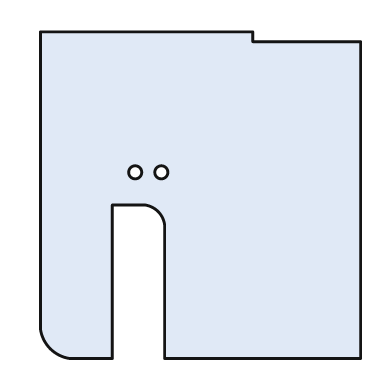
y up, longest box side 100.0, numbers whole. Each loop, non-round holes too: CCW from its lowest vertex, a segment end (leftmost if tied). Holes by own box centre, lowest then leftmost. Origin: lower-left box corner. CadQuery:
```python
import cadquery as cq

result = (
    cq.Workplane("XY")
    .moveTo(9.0, 0.0)
    .lineTo(22.0, 0.0)
    .lineTo(22.0, 47.0)
    .lineTo(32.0, 47.0)
    .threePointArc((36.0, 45.0), (38.0, 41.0))
    .lineTo(38.0, 0.0)
    .lineTo(98.0, 0.0)
    .lineTo(98.0, 97.0)
    .lineTo(65.0, 97.0)
    .lineTo(65.0, 100.0)
    .lineTo(0.0, 100.0)
    .lineTo(0.0, 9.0)
    .threePointArc((3.0, 3.0), (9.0, 0.0))
    .close()
    .moveTo(29.0, 57.0)
    .circle(2.0)
    .moveTo(37.0, 57.0)
    .circle(2.0)
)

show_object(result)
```